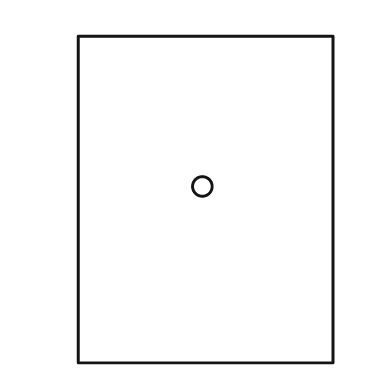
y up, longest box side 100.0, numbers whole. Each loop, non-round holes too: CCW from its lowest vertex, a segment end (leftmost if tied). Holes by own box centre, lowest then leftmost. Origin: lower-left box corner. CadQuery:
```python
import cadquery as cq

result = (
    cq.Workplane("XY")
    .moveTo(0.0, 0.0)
    .lineTo(78.0, 0.0)
    .lineTo(78.0, 100.0)
    .lineTo(0.0, 100.0)
    .close()
    .moveTo(38.0, 54.0)
    .circle(3.0)
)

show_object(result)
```